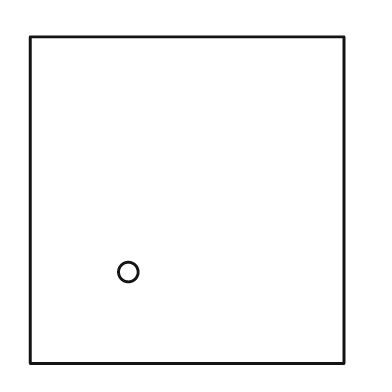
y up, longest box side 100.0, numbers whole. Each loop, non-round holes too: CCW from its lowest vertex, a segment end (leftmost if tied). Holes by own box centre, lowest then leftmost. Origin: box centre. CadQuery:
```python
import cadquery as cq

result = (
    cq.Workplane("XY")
    .moveTo(-48.0, -50.0)
    .lineTo(48.0, -50.0)
    .lineTo(48.0, 50.0)
    .lineTo(-48.0, 50.0)
    .close()
    .moveTo(-18.0, -22.0)
    .circle(3.0)
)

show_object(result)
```